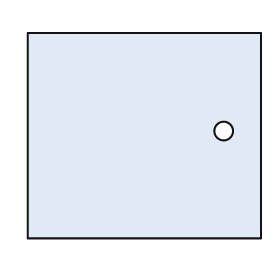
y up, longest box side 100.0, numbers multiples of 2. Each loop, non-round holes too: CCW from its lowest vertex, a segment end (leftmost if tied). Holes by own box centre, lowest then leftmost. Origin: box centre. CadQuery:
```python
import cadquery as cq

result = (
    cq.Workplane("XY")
    .moveTo(-50.0, -44.0)
    .lineTo(50.0, -44.0)
    .lineTo(50.0, 44.0)
    .lineTo(-50.0, 44.0)
    .close()
    .moveTo(34.0, 2.0)
    .circle(4.0)
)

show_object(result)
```